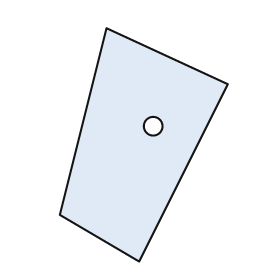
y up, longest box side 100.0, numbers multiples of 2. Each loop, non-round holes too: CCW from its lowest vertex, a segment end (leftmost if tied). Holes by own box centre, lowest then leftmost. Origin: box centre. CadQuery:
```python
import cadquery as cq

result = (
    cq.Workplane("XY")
    .moveTo(-2.0, -50.0)
    .lineTo(36.0, 26.0)
    .lineTo(-16.0, 50.0)
    .lineTo(-36.0, -30.0)
    .close()
    .moveTo(4.0, 8.0)
    .circle(4.0)
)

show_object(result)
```